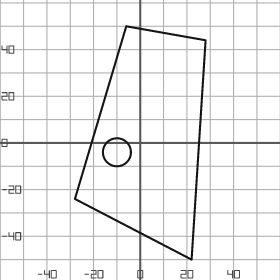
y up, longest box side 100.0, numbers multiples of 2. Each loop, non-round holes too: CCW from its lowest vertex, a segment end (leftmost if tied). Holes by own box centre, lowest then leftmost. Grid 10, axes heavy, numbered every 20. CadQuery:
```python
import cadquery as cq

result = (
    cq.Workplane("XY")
    .moveTo(22.0, -50.0)
    .lineTo(28.0, 44.0)
    .lineTo(-6.0, 50.0)
    .lineTo(-28.0, -24.0)
    .close()
    .moveTo(-10.0, -4.0)
    .circle(6.0)
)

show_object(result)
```